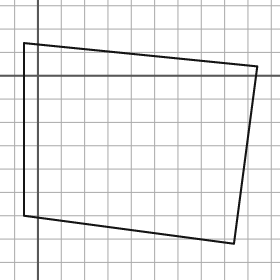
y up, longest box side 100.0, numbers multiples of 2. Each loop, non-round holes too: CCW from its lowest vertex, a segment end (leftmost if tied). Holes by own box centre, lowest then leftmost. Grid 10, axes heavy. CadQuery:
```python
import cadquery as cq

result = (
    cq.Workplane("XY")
    .moveTo(84.0, -72.0)
    .lineTo(94.0, 4.0)
    .lineTo(-6.0, 14.0)
    .lineTo(-6.0, -60.0)
    .close()
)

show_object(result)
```